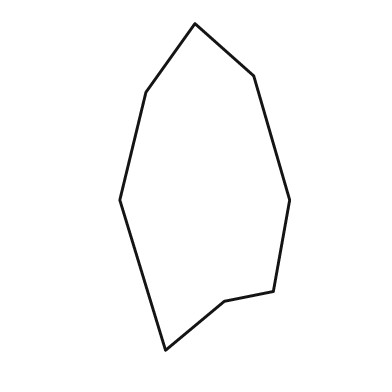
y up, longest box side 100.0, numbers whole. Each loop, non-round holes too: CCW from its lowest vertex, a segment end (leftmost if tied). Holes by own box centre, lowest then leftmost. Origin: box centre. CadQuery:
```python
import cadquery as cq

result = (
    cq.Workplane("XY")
    .moveTo(-12.0, -50.0)
    .lineTo(6.0, -35.0)
    .lineTo(21.0, -32.0)
    .lineTo(26.0, -4.0)
    .lineTo(15.0, 34.0)
    .lineTo(-3.0, 50.0)
    .lineTo(-18.0, 29.0)
    .lineTo(-26.0, -4.0)
    .close()
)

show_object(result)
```